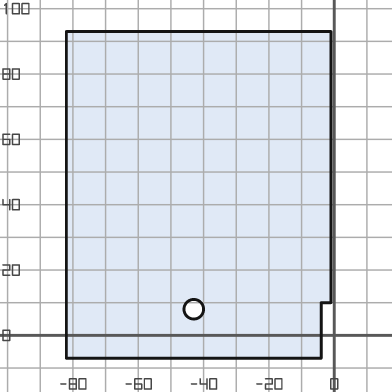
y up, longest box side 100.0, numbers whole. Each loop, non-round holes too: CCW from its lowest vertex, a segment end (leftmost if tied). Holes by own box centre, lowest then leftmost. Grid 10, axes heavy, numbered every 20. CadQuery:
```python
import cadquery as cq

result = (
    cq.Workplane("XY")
    .moveTo(-82.0, -7.0)
    .lineTo(-4.0, -7.0)
    .lineTo(-4.0, 10.0)
    .lineTo(-1.0, 10.0)
    .lineTo(-1.0, 93.0)
    .lineTo(-82.0, 93.0)
    .close()
    .moveTo(-43.0, 8.0)
    .circle(3.0)
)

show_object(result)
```